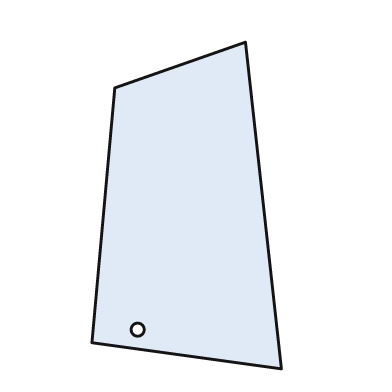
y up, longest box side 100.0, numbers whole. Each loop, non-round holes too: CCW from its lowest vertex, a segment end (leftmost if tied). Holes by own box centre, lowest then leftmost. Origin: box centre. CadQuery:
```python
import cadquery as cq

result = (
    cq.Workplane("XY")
    .moveTo(29.0, -50.0)
    .lineTo(18.0, 50.0)
    .lineTo(-22.0, 36.0)
    .lineTo(-29.0, -42.0)
    .close()
    .moveTo(-15.0, -38.0)
    .circle(2.0)
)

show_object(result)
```